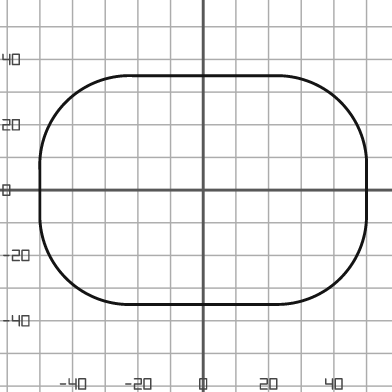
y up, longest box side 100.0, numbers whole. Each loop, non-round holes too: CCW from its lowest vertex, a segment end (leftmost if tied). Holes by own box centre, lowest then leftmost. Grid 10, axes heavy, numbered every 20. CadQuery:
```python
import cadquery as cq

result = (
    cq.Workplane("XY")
    .moveTo(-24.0, -35.0)
    .lineTo(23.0, -35.0)
    .threePointArc((42.0, -27.0), (50.0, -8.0))
    .lineTo(50.0, 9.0)
    .threePointArc((42.0, 27.0), (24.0, 35.0))
    .lineTo(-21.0, 35.0)
    .threePointArc((-42.0, 27.0), (-50.0, 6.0))
    .lineTo(-50.0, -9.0)
    .threePointArc((-42.0, -27.0), (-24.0, -35.0))
    .close()
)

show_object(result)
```